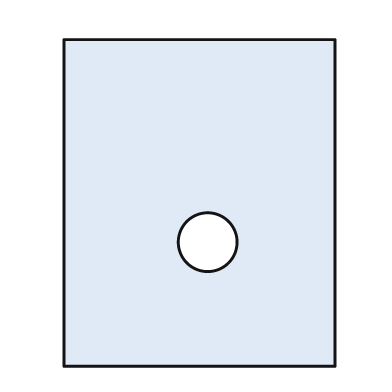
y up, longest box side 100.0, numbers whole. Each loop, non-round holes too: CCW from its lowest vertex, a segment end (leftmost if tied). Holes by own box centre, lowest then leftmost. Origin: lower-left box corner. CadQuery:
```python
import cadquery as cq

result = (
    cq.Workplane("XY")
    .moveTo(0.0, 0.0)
    .lineTo(83.0, 0.0)
    .lineTo(83.0, 100.0)
    .lineTo(0.0, 100.0)
    .close()
    .moveTo(44.0, 38.0)
    .circle(9.0)
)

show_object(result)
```